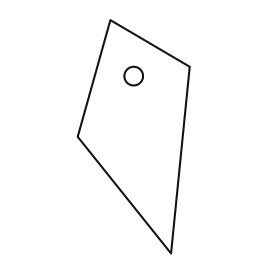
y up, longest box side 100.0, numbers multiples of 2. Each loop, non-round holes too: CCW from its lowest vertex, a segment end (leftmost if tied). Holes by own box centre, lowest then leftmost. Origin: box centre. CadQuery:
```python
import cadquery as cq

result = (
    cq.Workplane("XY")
    .moveTo(16.0, -50.0)
    .lineTo(24.0, 30.0)
    .lineTo(-10.0, 50.0)
    .lineTo(-24.0, 0.0)
    .close()
    .moveTo(0.0, 26.0)
    .circle(4.0)
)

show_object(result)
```